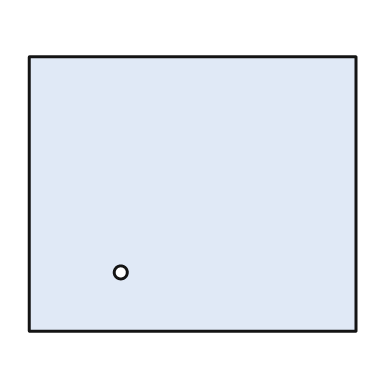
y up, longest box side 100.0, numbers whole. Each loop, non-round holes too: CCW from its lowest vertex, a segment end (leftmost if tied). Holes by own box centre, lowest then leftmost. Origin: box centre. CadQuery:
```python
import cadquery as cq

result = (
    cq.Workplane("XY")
    .moveTo(-50.0, -42.0)
    .lineTo(50.0, -42.0)
    .lineTo(50.0, 42.0)
    .lineTo(-50.0, 42.0)
    .close()
    .moveTo(-22.0, -24.0)
    .circle(2.0)
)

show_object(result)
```